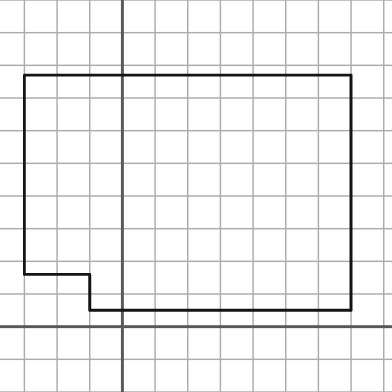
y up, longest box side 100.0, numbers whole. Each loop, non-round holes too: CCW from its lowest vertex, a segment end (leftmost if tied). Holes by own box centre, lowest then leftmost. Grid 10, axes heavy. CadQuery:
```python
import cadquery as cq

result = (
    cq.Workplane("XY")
    .moveTo(-10.0, 5.0)
    .lineTo(70.0, 5.0)
    .lineTo(70.0, 77.0)
    .lineTo(-30.0, 77.0)
    .lineTo(-30.0, 16.0)
    .lineTo(-10.0, 16.0)
    .close()
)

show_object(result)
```